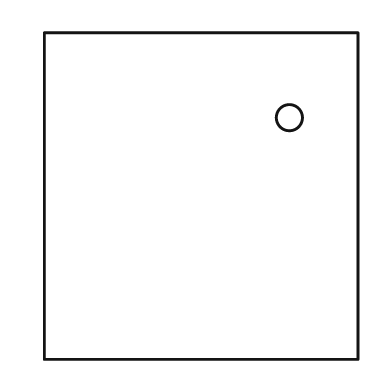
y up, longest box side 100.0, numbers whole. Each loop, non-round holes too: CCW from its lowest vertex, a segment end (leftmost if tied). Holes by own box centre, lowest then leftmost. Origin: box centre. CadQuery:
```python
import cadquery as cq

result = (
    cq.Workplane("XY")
    .moveTo(-48.0, -50.0)
    .lineTo(48.0, -50.0)
    .lineTo(48.0, 50.0)
    .lineTo(-48.0, 50.0)
    .close()
    .moveTo(27.0, 24.0)
    .circle(4.0)
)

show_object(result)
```